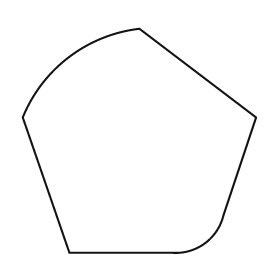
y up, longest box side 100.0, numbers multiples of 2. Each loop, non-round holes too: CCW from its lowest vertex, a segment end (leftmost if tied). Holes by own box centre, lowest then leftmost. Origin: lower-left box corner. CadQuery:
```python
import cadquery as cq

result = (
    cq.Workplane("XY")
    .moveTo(20.0, 0.0)
    .lineTo(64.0, 0.0)
    .threePointArc((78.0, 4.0), (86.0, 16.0))
    .lineTo(100.0, 58.0)
    .lineTo(50.0, 96.0)
    .threePointArc((20.0, 84.0), (0.0, 58.0))
    .close()
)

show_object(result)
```